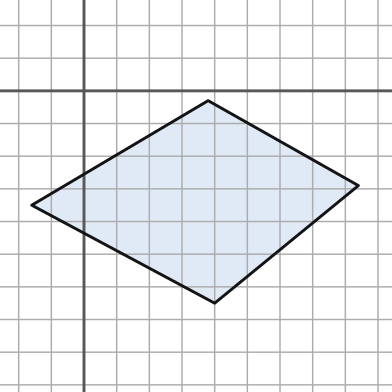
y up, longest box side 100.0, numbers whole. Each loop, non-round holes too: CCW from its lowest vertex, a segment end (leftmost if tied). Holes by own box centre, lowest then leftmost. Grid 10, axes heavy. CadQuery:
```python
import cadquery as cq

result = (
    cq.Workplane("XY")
    .moveTo(40.0, -65.0)
    .lineTo(84.0, -29.0)
    .lineTo(38.0, -3.0)
    .lineTo(-16.0, -35.0)
    .close()
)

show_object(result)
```